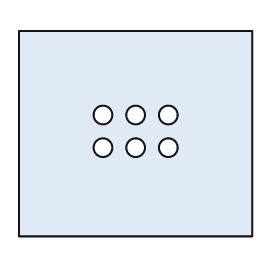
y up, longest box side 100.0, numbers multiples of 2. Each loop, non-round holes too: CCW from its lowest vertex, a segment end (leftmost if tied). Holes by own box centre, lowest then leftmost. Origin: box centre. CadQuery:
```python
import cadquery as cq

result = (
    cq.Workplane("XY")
    .moveTo(-50.0, -44.0)
    .lineTo(50.0, -44.0)
    .lineTo(50.0, 44.0)
    .lineTo(-50.0, 44.0)
    .close()
    .moveTo(-14.0, -6.0)
    .circle(4.0)
    .moveTo(0.0, -6.0)
    .circle(4.0)
    .moveTo(14.0, -6.0)
    .circle(4.0)
    .moveTo(-14.0, 8.0)
    .circle(4.0)
    .moveTo(0.0, 8.0)
    .circle(4.0)
    .moveTo(14.0, 8.0)
    .circle(4.0)
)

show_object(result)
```